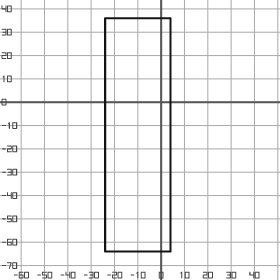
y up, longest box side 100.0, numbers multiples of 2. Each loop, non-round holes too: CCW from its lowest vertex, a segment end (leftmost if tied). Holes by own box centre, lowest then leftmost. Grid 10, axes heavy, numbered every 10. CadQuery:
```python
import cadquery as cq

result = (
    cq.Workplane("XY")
    .moveTo(-24.0, -64.0)
    .lineTo(4.0, -64.0)
    .lineTo(4.0, 36.0)
    .lineTo(-24.0, 36.0)
    .close()
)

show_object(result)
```